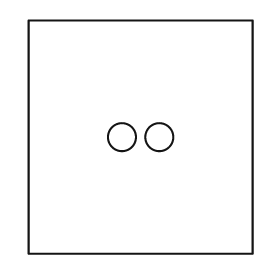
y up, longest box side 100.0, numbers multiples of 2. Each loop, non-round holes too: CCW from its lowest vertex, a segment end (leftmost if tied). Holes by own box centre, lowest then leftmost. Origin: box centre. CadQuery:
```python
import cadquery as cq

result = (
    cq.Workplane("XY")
    .moveTo(-48.0, -50.0)
    .lineTo(48.0, -50.0)
    .lineTo(48.0, 50.0)
    .lineTo(-48.0, 50.0)
    .close()
    .moveTo(-8.0, 0.0)
    .circle(6.0)
    .moveTo(8.0, 0.0)
    .circle(6.0)
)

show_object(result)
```